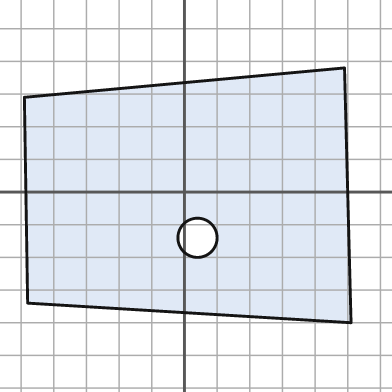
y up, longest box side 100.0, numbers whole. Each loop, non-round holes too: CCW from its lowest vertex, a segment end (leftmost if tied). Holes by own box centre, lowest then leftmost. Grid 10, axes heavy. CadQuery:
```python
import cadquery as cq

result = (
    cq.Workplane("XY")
    .moveTo(51.0, -40.0)
    .lineTo(49.0, 38.0)
    .lineTo(-49.0, 29.0)
    .lineTo(-48.0, -34.0)
    .close()
    .moveTo(4.0, -14.0)
    .circle(6.0)
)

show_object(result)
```